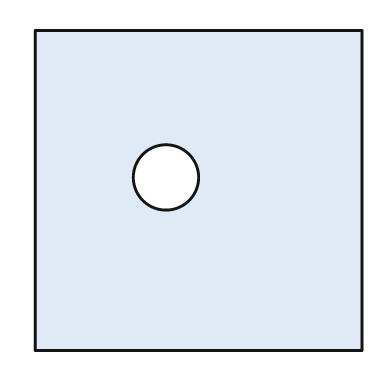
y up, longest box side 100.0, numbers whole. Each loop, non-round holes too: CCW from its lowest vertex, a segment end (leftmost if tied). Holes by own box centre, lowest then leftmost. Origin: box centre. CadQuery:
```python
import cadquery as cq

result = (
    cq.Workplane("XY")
    .moveTo(-50.0, -49.0)
    .lineTo(50.0, -49.0)
    .lineTo(50.0, 49.0)
    .lineTo(-50.0, 49.0)
    .close()
    .moveTo(-10.0, 4.0)
    .circle(10.0)
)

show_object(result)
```